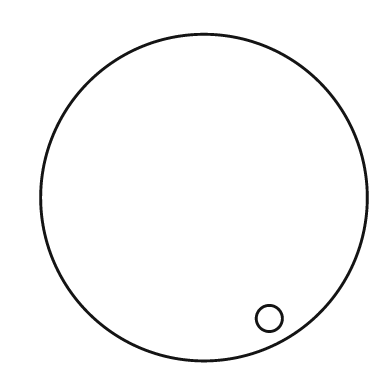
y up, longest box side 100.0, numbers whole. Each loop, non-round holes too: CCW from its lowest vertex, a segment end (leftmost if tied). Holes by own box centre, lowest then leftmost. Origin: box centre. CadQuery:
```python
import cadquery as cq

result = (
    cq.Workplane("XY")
    .moveTo(0.0, 0.0)
    .circle(50.0)
    .moveTo(20.0, -37.0)
    .circle(4.0)
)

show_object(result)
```